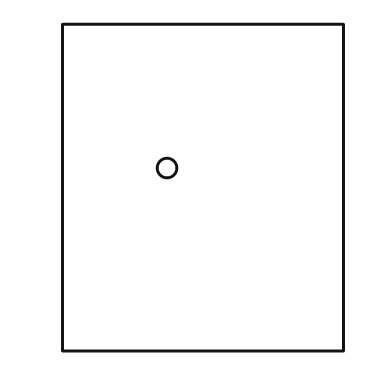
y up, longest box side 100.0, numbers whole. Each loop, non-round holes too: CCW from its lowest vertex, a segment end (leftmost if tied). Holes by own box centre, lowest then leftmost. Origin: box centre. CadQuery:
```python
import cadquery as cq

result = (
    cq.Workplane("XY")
    .moveTo(-43.0, -50.0)
    .lineTo(43.0, -50.0)
    .lineTo(43.0, 50.0)
    .lineTo(-43.0, 50.0)
    .close()
    .moveTo(-11.0, 6.0)
    .circle(3.0)
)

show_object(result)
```